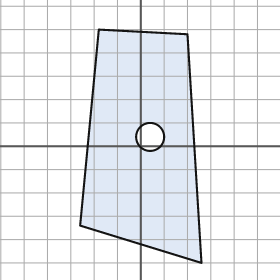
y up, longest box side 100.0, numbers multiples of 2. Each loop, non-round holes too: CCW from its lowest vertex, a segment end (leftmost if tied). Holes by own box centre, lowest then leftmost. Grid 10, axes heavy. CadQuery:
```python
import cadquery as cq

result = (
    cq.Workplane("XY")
    .moveTo(26.0, -50.0)
    .lineTo(20.0, 48.0)
    .lineTo(-18.0, 50.0)
    .lineTo(-26.0, -34.0)
    .close()
    .moveTo(4.0, 4.0)
    .circle(6.0)
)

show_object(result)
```